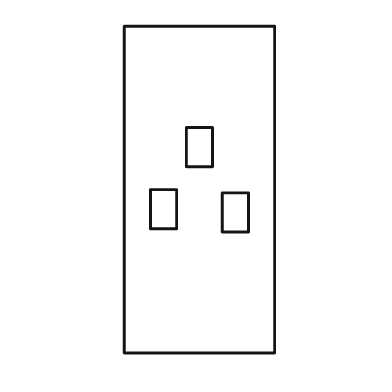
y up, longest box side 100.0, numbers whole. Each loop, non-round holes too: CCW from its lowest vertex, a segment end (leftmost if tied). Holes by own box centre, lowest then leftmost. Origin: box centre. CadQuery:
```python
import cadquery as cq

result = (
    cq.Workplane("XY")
    .moveTo(-23.0, -50.0)
    .lineTo(23.0, -50.0)
    .lineTo(23.0, 50.0)
    .lineTo(-23.0, 50.0)
    .close()
    .moveTo(7.0, -13.0)
    .lineTo(15.0, -13.0)
    .lineTo(15.0, -1.0)
    .lineTo(7.0, -1.0)
    .close()
    .moveTo(-15.0, -12.0)
    .lineTo(-7.0, -12.0)
    .lineTo(-7.0, 0.0)
    .lineTo(-15.0, 0.0)
    .close()
    .moveTo(-4.0, 7.0)
    .lineTo(4.0, 7.0)
    .lineTo(4.0, 19.0)
    .lineTo(-4.0, 19.0)
    .close()
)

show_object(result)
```